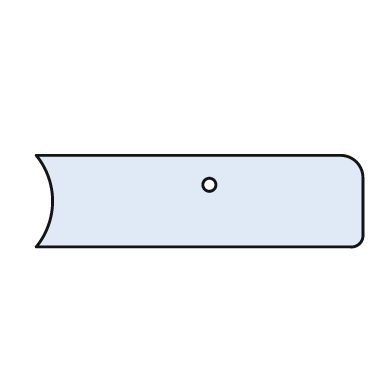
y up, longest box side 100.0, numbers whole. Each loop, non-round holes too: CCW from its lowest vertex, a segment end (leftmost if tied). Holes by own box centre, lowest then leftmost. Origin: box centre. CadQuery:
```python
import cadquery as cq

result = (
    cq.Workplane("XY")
    .moveTo(-50.0, -14.0)
    .lineTo(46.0, -14.0)
    .threePointArc((49.0, -13.0), (50.0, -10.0))
    .lineTo(50.0, 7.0)
    .threePointArc((48.0, 12.0), (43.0, 14.0))
    .lineTo(-50.0, 14.0)
    .threePointArc((-45.0, 0.0), (-50.0, -14.0))
    .close()
    .moveTo(3.0, 5.0)
    .circle(2.0)
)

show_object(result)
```